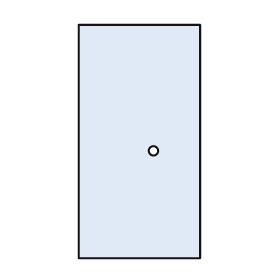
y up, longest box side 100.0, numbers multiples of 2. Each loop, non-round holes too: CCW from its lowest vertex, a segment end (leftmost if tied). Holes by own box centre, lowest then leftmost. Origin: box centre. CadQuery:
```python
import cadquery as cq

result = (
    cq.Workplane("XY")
    .moveTo(-26.0, -50.0)
    .lineTo(26.0, -50.0)
    .lineTo(26.0, 50.0)
    .lineTo(-26.0, 50.0)
    .close()
    .moveTo(6.0, -4.0)
    .circle(2.0)
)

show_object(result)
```